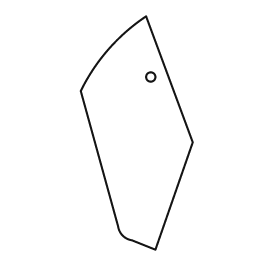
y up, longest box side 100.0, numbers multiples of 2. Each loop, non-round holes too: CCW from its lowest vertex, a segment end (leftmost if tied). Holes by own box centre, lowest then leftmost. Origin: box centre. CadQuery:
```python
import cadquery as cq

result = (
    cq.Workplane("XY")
    .moveTo(8.0, -50.0)
    .lineTo(24.0, -4.0)
    .lineTo(4.0, 50.0)
    .threePointArc((-12.0, 36.0), (-24.0, 18.0))
    .lineTo(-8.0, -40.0)
    .threePointArc((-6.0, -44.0), (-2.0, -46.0))
    .close()
    .moveTo(6.0, 24.0)
    .circle(2.0)
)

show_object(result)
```